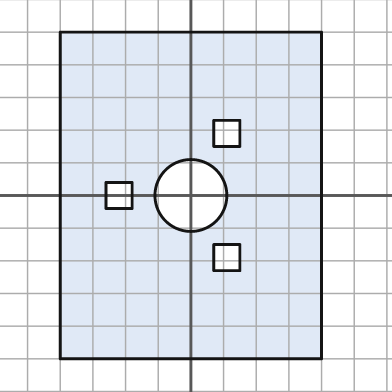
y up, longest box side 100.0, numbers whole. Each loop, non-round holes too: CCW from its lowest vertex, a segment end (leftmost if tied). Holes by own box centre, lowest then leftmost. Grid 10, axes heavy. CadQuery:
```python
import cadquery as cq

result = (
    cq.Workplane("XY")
    .moveTo(-40.0, -50.0)
    .lineTo(40.0, -50.0)
    .lineTo(40.0, 50.0)
    .lineTo(-40.0, 50.0)
    .close()
    .moveTo(7.0, -23.0)
    .lineTo(15.0, -23.0)
    .lineTo(15.0, -15.0)
    .lineTo(7.0, -15.0)
    .close()
    .moveTo(-26.0, -4.0)
    .lineTo(-18.0, -4.0)
    .lineTo(-18.0, 4.0)
    .lineTo(-26.0, 4.0)
    .close()
    .moveTo(0.0, 0.0)
    .circle(11.0)
    .moveTo(7.0, 15.0)
    .lineTo(15.0, 15.0)
    .lineTo(15.0, 23.0)
    .lineTo(7.0, 23.0)
    .close()
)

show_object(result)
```